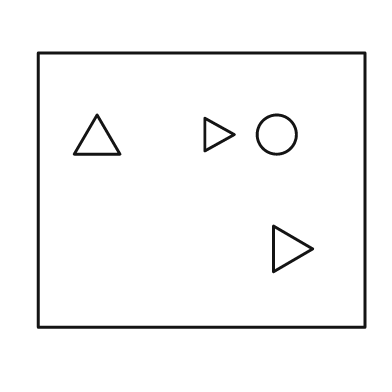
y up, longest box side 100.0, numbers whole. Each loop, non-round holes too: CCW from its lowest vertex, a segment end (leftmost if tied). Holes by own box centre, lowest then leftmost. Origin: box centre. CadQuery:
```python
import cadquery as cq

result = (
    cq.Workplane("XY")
    .moveTo(-50.0, -42.0)
    .lineTo(50.0, -42.0)
    .lineTo(50.0, 42.0)
    .lineTo(-50.0, 42.0)
    .close()
    .moveTo(22.0, -25.0)
    .lineTo(34.0, -18.0)
    .lineTo(22.0, -11.0)
    .close()
    .moveTo(-39.0, 11.0)
    .lineTo(-25.0, 11.0)
    .lineTo(-32.0, 23.0)
    .close()
    .moveTo(1.0, 12.0)
    .lineTo(10.0, 17.0)
    .lineTo(1.0, 22.0)
    .close()
    .moveTo(23.0, 17.0)
    .circle(6.0)
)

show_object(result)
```